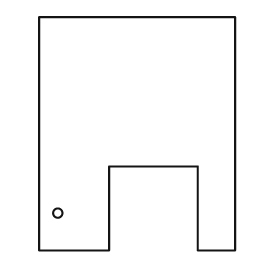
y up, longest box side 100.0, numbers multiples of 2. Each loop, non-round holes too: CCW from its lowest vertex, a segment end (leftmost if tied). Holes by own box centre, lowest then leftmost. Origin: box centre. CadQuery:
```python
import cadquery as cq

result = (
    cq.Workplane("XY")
    .moveTo(-42.0, -50.0)
    .lineTo(-12.0, -50.0)
    .lineTo(-12.0, -14.0)
    .lineTo(26.0, -14.0)
    .lineTo(26.0, -50.0)
    .lineTo(42.0, -50.0)
    .lineTo(42.0, 50.0)
    .lineTo(-42.0, 50.0)
    .close()
    .moveTo(-34.0, -34.0)
    .circle(2.0)
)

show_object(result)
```